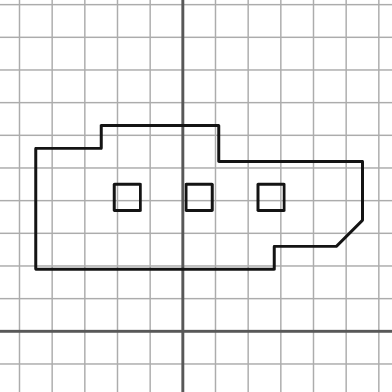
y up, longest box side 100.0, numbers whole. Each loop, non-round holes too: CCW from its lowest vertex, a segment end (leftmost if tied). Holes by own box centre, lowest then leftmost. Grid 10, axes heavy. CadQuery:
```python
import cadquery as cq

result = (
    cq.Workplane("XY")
    .moveTo(-45.0, 19.0)
    .lineTo(28.0, 19.0)
    .lineTo(28.0, 26.0)
    .lineTo(47.0, 26.0)
    .lineTo(55.0, 34.0)
    .lineTo(55.0, 52.0)
    .lineTo(11.0, 52.0)
    .lineTo(11.0, 63.0)
    .lineTo(-25.0, 63.0)
    .lineTo(-25.0, 56.0)
    .lineTo(-45.0, 56.0)
    .close()
    .moveTo(-21.0, 37.0)
    .lineTo(-13.0, 37.0)
    .lineTo(-13.0, 45.0)
    .lineTo(-21.0, 45.0)
    .close()
    .moveTo(1.0, 37.0)
    .lineTo(9.0, 37.0)
    .lineTo(9.0, 45.0)
    .lineTo(1.0, 45.0)
    .close()
    .moveTo(23.0, 37.0)
    .lineTo(31.0, 37.0)
    .lineTo(31.0, 45.0)
    .lineTo(23.0, 45.0)
    .close()
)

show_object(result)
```